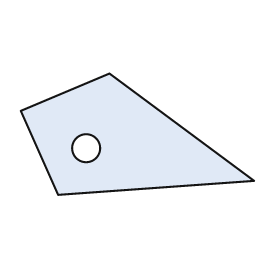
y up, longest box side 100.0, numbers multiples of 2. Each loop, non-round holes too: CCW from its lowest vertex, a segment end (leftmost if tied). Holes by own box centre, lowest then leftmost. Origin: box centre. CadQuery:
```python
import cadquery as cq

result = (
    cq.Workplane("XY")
    .moveTo(-34.0, -26.0)
    .lineTo(50.0, -20.0)
    .lineTo(-12.0, 26.0)
    .lineTo(-50.0, 10.0)
    .close()
    .moveTo(-22.0, -6.0)
    .circle(6.0)
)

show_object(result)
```